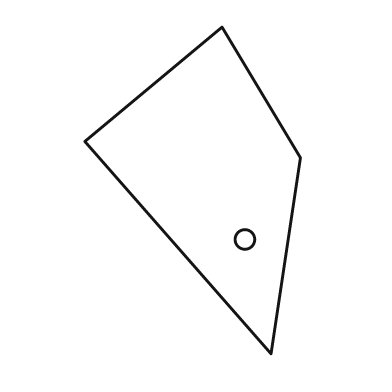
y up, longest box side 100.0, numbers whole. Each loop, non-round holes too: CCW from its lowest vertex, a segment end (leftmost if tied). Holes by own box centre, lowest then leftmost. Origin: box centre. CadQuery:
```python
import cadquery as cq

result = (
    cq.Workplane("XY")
    .moveTo(24.0, -50.0)
    .lineTo(33.0, 10.0)
    .lineTo(9.0, 50.0)
    .lineTo(-33.0, 15.0)
    .close()
    .moveTo(16.0, -15.0)
    .circle(3.0)
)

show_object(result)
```